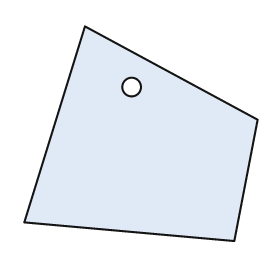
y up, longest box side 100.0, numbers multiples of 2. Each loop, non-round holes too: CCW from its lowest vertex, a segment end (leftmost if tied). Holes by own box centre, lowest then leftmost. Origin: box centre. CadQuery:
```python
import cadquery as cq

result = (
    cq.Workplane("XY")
    .moveTo(40.0, -46.0)
    .lineTo(50.0, 6.0)
    .lineTo(-24.0, 46.0)
    .lineTo(-50.0, -38.0)
    .close()
    .moveTo(-4.0, 20.0)
    .circle(4.0)
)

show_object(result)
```